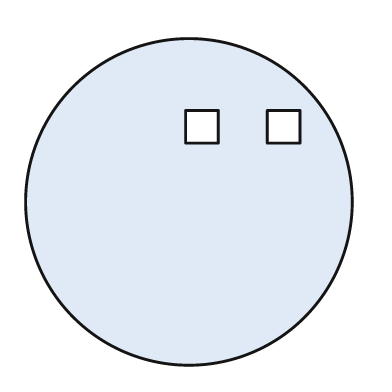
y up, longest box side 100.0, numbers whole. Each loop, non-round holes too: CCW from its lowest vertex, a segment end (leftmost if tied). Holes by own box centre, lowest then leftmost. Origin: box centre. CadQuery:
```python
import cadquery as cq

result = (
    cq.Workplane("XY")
    .moveTo(0.0, 0.0)
    .circle(50.0)
    .moveTo(-1.0, 18.0)
    .lineTo(9.0, 18.0)
    .lineTo(9.0, 28.0)
    .lineTo(-1.0, 28.0)
    .close()
    .moveTo(24.0, 18.0)
    .lineTo(34.0, 18.0)
    .lineTo(34.0, 28.0)
    .lineTo(24.0, 28.0)
    .close()
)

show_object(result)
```